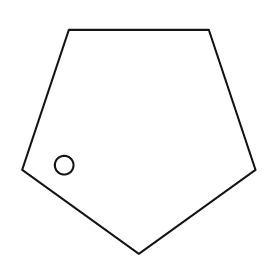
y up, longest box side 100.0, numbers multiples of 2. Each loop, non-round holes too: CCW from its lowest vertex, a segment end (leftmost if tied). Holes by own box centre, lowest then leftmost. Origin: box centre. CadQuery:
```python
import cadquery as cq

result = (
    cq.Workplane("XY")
    .moveTo(0.0, -48.0)
    .lineTo(50.0, -12.0)
    .lineTo(30.0, 48.0)
    .lineTo(-30.0, 48.0)
    .lineTo(-50.0, -12.0)
    .close()
    .moveTo(-32.0, -10.0)
    .circle(4.0)
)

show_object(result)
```